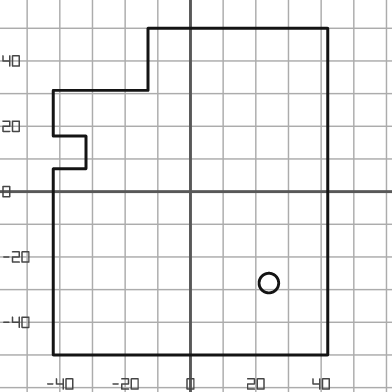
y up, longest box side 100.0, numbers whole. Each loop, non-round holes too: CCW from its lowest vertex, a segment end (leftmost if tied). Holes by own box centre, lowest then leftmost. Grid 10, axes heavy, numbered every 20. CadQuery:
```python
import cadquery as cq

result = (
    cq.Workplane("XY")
    .moveTo(-42.0, -50.0)
    .lineTo(42.0, -50.0)
    .lineTo(42.0, 50.0)
    .lineTo(-13.0, 50.0)
    .lineTo(-13.0, 31.0)
    .lineTo(-42.0, 31.0)
    .lineTo(-42.0, 17.0)
    .lineTo(-32.0, 17.0)
    .lineTo(-32.0, 7.0)
    .lineTo(-42.0, 7.0)
    .close()
    .moveTo(24.0, -28.0)
    .circle(3.0)
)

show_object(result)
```